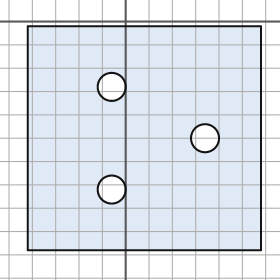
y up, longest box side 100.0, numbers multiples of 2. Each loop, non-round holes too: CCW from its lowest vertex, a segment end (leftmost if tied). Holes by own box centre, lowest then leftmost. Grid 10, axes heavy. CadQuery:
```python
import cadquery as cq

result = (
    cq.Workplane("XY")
    .moveTo(-42.0, -98.0)
    .lineTo(58.0, -98.0)
    .lineTo(58.0, -2.0)
    .lineTo(-42.0, -2.0)
    .close()
    .moveTo(-6.0, -72.0)
    .circle(6.0)
    .moveTo(34.0, -50.0)
    .circle(6.0)
    .moveTo(-6.0, -28.0)
    .circle(6.0)
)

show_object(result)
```